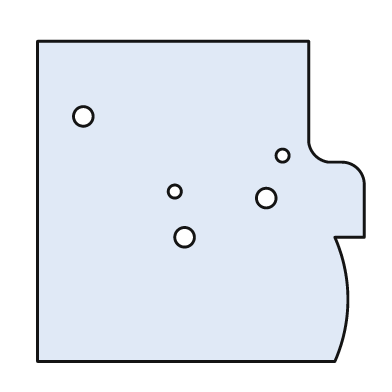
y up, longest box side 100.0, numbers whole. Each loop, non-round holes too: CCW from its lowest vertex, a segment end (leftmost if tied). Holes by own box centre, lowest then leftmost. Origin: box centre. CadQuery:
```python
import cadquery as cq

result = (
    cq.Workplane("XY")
    .moveTo(-50.0, -49.0)
    .lineTo(41.0, -49.0)
    .threePointArc((45.0, -30.0), (41.0, -11.0))
    .lineTo(50.0, -11.0)
    .lineTo(50.0, 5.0)
    .threePointArc((48.0, 10.0), (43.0, 12.0))
    .lineTo(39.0, 12.0)
    .threePointArc((35.0, 14.0), (33.0, 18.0))
    .lineTo(33.0, 49.0)
    .lineTo(-50.0, 49.0)
    .close()
    .moveTo(-5.0, -11.0)
    .circle(3.0)
    .moveTo(20.0, 1.0)
    .circle(3.0)
    .moveTo(-8.0, 3.0)
    .circle(2.0)
    .moveTo(25.0, 14.0)
    .circle(2.0)
    .moveTo(-36.0, 26.0)
    .circle(3.0)
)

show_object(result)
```